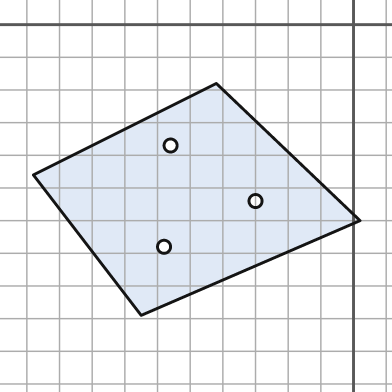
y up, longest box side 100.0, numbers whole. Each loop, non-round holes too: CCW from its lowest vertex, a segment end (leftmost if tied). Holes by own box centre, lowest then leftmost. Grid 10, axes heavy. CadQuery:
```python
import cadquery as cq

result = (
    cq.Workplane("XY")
    .moveTo(-65.0, -89.0)
    .lineTo(2.0, -60.0)
    .lineTo(-42.0, -18.0)
    .lineTo(-98.0, -46.0)
    .close()
    .moveTo(-58.0, -68.0)
    .circle(2.0)
    .moveTo(-30.0, -54.0)
    .circle(2.0)
    .moveTo(-56.0, -37.0)
    .circle(2.0)
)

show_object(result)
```